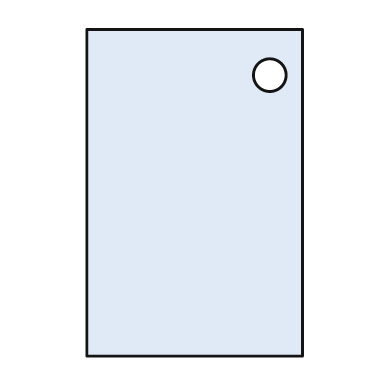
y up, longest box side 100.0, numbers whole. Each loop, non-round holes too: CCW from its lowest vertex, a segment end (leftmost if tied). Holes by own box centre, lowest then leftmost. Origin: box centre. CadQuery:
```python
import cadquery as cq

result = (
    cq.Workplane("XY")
    .moveTo(-33.0, -50.0)
    .lineTo(33.0, -50.0)
    .lineTo(33.0, 50.0)
    .lineTo(-33.0, 50.0)
    .close()
    .moveTo(23.0, 36.0)
    .circle(5.0)
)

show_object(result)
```